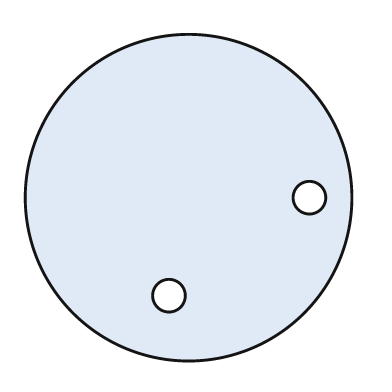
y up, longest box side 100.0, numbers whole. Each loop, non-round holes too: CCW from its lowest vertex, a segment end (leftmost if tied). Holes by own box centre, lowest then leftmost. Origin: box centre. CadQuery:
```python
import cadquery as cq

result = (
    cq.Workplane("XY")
    .moveTo(0.0, 0.0)
    .circle(50.0)
    .moveTo(-6.0, -30.0)
    .circle(5.0)
    .moveTo(37.0, 0.0)
    .circle(5.0)
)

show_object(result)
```